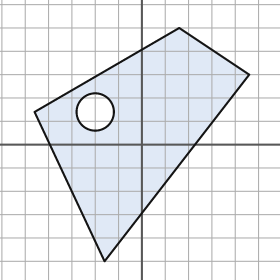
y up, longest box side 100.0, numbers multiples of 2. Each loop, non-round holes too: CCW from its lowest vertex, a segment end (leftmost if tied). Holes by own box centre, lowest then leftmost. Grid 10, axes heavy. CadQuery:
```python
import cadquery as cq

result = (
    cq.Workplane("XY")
    .moveTo(-16.0, -50.0)
    .lineTo(46.0, 30.0)
    .lineTo(16.0, 50.0)
    .lineTo(-46.0, 14.0)
    .close()
    .moveTo(-20.0, 14.0)
    .circle(8.0)
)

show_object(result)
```